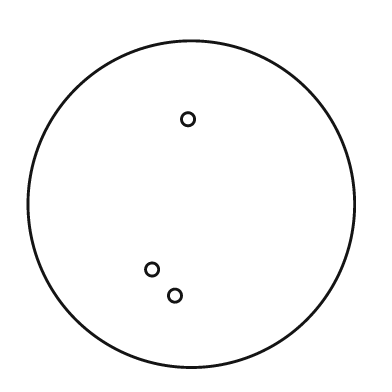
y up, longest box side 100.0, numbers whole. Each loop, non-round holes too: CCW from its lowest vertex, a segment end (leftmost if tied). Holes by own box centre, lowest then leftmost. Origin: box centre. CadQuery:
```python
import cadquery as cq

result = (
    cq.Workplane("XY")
    .moveTo(0.0, 0.0)
    .circle(50.0)
    .moveTo(-5.0, -28.0)
    .circle(2.0)
    .moveTo(-12.0, -20.0)
    .circle(2.0)
    .moveTo(-1.0, 26.0)
    .circle(2.0)
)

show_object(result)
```